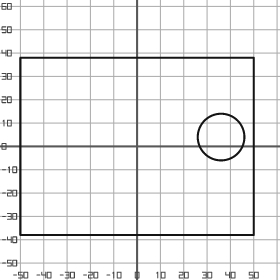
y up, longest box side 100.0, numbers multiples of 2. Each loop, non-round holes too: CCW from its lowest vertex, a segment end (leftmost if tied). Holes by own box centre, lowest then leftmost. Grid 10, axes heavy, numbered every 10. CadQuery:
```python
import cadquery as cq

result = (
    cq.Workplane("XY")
    .moveTo(-50.0, -38.0)
    .lineTo(50.0, -38.0)
    .lineTo(50.0, 38.0)
    .lineTo(-50.0, 38.0)
    .close()
    .moveTo(36.0, 4.0)
    .circle(10.0)
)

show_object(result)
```